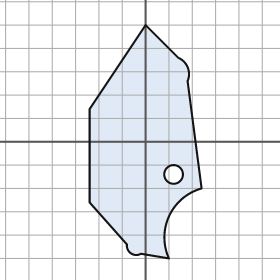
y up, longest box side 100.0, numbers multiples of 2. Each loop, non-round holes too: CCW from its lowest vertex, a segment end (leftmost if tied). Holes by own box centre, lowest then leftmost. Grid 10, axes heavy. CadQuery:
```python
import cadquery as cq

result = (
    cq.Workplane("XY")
    .moveTo(10.0, -50.0)
    .threePointArc((10.0, -32.0), (24.0, -20.0))
    .lineTo(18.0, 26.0)
    .threePointArc((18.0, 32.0), (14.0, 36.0))
    .lineTo(0.0, 50.0)
    .lineTo(-24.0, 14.0)
    .lineTo(-24.0, -26.0)
    .lineTo(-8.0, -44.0)
    .threePointArc((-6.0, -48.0), (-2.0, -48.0))
    .close()
    .moveTo(12.0, -14.0)
    .circle(4.0)
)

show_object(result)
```